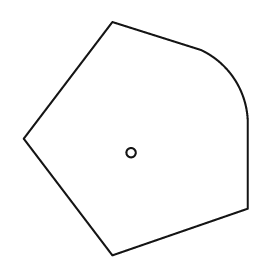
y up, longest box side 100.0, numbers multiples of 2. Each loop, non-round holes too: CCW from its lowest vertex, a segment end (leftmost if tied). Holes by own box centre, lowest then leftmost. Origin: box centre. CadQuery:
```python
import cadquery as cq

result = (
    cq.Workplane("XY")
    .moveTo(-10.0, -50.0)
    .lineTo(48.0, -30.0)
    .lineTo(48.0, 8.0)
    .threePointArc((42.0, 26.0), (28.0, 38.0))
    .lineTo(-10.0, 50.0)
    .lineTo(-48.0, 0.0)
    .close()
    .moveTo(-2.0, -6.0)
    .circle(2.0)
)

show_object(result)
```